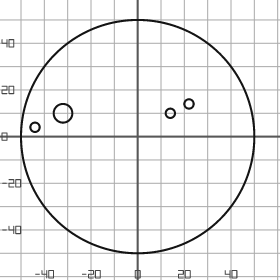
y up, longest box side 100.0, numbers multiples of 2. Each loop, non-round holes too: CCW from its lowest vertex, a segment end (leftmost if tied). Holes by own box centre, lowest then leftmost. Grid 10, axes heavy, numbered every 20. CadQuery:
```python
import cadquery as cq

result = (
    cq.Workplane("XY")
    .moveTo(0.0, 0.0)
    .circle(50.0)
    .moveTo(-44.0, 4.0)
    .circle(2.0)
    .moveTo(-32.0, 10.0)
    .circle(4.0)
    .moveTo(14.0, 10.0)
    .circle(2.0)
    .moveTo(22.0, 14.0)
    .circle(2.0)
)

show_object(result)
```